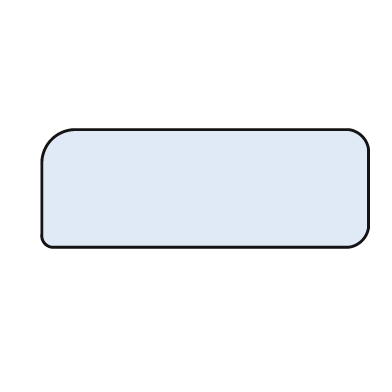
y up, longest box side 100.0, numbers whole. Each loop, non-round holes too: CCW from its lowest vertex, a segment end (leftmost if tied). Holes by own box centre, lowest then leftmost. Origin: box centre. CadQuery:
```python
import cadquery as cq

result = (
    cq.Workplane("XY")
    .moveTo(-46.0, -18.0)
    .lineTo(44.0, -18.0)
    .threePointArc((48.0, -16.0), (50.0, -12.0))
    .lineTo(50.0, 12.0)
    .threePointArc((48.0, 16.0), (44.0, 18.0))
    .lineTo(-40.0, 18.0)
    .threePointArc((-47.0, 15.0), (-50.0, 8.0))
    .lineTo(-50.0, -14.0)
    .threePointArc((-49.0, -17.0), (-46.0, -18.0))
    .close()
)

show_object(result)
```